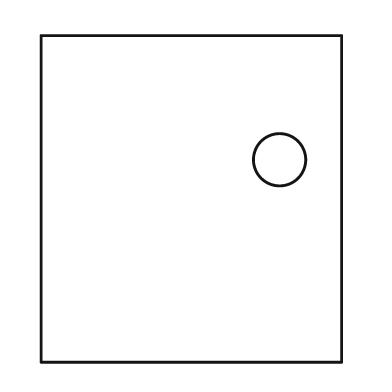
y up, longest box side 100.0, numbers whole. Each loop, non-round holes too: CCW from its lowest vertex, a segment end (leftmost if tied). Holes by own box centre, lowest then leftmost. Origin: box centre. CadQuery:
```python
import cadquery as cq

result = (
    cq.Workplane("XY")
    .moveTo(-46.0, -50.0)
    .lineTo(46.0, -50.0)
    .lineTo(46.0, 50.0)
    .lineTo(-46.0, 50.0)
    .close()
    .moveTo(27.0, 12.0)
    .circle(8.0)
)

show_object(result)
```